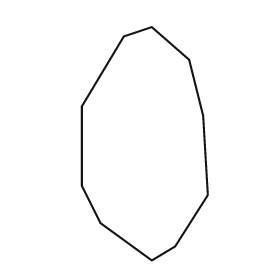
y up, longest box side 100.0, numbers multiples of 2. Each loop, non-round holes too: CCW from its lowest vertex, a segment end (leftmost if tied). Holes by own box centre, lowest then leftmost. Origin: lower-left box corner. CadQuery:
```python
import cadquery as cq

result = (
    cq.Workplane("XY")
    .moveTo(30.0, 0.0)
    .lineTo(40.0, 6.0)
    .lineTo(54.0, 28.0)
    .lineTo(52.0, 62.0)
    .lineTo(46.0, 86.0)
    .lineTo(30.0, 100.0)
    .lineTo(18.0, 96.0)
    .lineTo(0.0, 66.0)
    .lineTo(0.0, 32.0)
    .lineTo(8.0, 16.0)
    .close()
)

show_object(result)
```